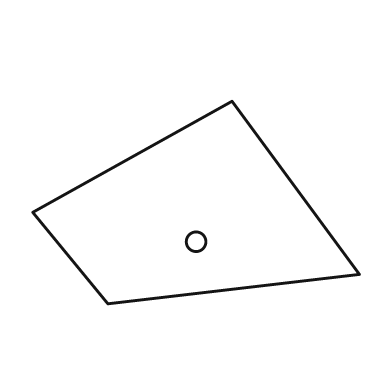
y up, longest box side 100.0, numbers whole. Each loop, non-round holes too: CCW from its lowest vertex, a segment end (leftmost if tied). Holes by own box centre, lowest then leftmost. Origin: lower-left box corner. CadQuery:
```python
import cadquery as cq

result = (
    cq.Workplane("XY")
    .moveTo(23.0, 0.0)
    .lineTo(100.0, 9.0)
    .lineTo(61.0, 62.0)
    .lineTo(0.0, 28.0)
    .close()
    .moveTo(50.0, 19.0)
    .circle(3.0)
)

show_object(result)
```